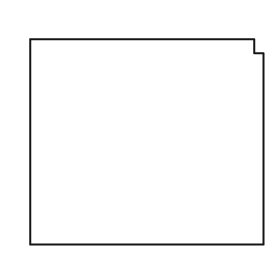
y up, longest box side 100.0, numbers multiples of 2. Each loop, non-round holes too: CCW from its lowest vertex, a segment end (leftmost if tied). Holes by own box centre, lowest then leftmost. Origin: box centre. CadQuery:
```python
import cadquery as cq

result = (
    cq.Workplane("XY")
    .moveTo(-50.0, -44.0)
    .lineTo(50.0, -44.0)
    .lineTo(50.0, 38.0)
    .lineTo(46.0, 38.0)
    .lineTo(46.0, 44.0)
    .lineTo(-50.0, 44.0)
    .close()
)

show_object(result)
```